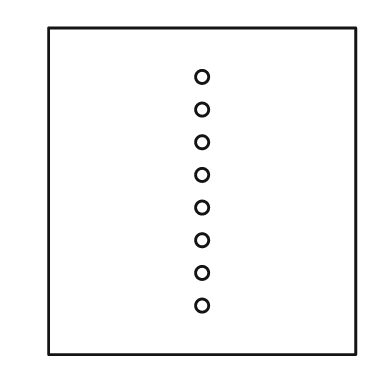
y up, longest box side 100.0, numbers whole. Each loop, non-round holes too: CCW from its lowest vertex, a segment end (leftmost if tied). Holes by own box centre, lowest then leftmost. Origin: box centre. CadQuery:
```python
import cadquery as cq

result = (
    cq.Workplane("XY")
    .moveTo(-47.0, -50.0)
    .lineTo(47.0, -50.0)
    .lineTo(47.0, 50.0)
    .lineTo(-47.0, 50.0)
    .close()
    .moveTo(0.0, -35.0)
    .circle(2.0)
    .moveTo(0.0, -25.0)
    .circle(2.0)
    .moveTo(0.0, -15.0)
    .circle(2.0)
    .moveTo(0.0, -5.0)
    .circle(2.0)
    .moveTo(0.0, 5.0)
    .circle(2.0)
    .moveTo(0.0, 15.0)
    .circle(2.0)
    .moveTo(0.0, 25.0)
    .circle(2.0)
    .moveTo(0.0, 35.0)
    .circle(2.0)
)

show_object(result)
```